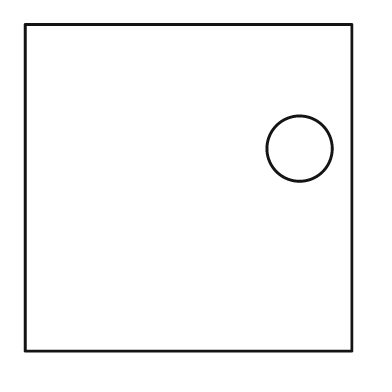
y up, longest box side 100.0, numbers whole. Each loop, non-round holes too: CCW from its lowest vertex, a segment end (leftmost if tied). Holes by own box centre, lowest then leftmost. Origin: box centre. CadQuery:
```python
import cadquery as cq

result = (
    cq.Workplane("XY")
    .moveTo(-50.0, -50.0)
    .lineTo(50.0, -50.0)
    .lineTo(50.0, 50.0)
    .lineTo(-50.0, 50.0)
    .close()
    .moveTo(34.0, 12.0)
    .circle(10.0)
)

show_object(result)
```